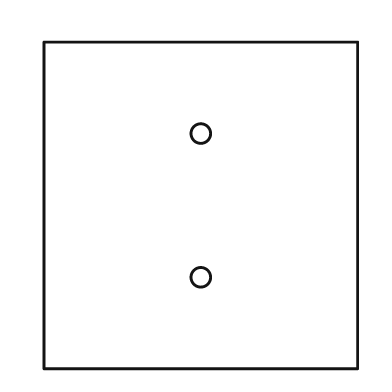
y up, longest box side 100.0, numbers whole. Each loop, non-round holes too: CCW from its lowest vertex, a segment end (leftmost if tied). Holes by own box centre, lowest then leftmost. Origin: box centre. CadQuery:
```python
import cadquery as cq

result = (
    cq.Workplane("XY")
    .moveTo(-48.0, -50.0)
    .lineTo(48.0, -50.0)
    .lineTo(48.0, 50.0)
    .lineTo(-48.0, 50.0)
    .close()
    .moveTo(0.0, -22.0)
    .circle(3.0)
    .moveTo(0.0, 22.0)
    .circle(3.0)
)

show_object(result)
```